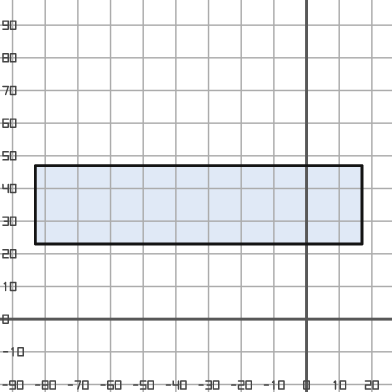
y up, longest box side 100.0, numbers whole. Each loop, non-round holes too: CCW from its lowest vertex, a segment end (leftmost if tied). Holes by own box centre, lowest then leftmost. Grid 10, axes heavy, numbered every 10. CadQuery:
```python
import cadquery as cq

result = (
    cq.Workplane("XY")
    .moveTo(-83.0, 23.0)
    .lineTo(17.0, 23.0)
    .lineTo(17.0, 47.0)
    .lineTo(-83.0, 47.0)
    .close()
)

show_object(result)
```